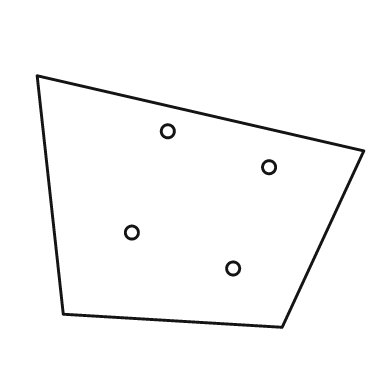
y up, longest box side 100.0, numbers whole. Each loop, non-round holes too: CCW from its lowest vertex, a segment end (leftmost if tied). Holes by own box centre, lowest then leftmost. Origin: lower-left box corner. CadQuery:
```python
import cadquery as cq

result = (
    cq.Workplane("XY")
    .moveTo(75.0, 0.0)
    .lineTo(100.0, 54.0)
    .lineTo(0.0, 77.0)
    .lineTo(8.0, 4.0)
    .close()
    .moveTo(60.0, 18.0)
    .circle(2.0)
    .moveTo(29.0, 29.0)
    .circle(2.0)
    .moveTo(71.0, 49.0)
    .circle(2.0)
    .moveTo(40.0, 60.0)
    .circle(2.0)
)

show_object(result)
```